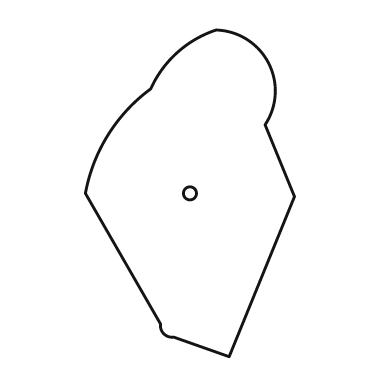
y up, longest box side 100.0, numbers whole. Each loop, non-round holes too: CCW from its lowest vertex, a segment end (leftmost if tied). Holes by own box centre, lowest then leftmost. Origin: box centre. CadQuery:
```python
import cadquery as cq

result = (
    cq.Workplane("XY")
    .moveTo(12.0, -50.0)
    .lineTo(32.0, -1.0)
    .lineTo(23.0, 21.0)
    .threePointArc((24.0, 40.0), (8.0, 50.0))
    .threePointArc((-4.0, 43.0), (-12.0, 32.0))
    .threePointArc((-25.0, 18.0), (-32.0, 0.0))
    .lineTo(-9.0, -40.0)
    .threePointArc((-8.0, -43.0), (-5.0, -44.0))
    .close()
    .moveTo(0.0, 0.0)
    .circle(2.0)
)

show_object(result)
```